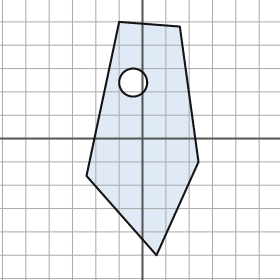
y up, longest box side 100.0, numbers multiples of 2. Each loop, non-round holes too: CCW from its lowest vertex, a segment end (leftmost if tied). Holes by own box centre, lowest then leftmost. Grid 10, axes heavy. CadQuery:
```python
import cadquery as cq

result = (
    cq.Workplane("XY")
    .moveTo(6.0, -50.0)
    .lineTo(24.0, -10.0)
    .lineTo(16.0, 48.0)
    .lineTo(-10.0, 50.0)
    .lineTo(-24.0, -16.0)
    .close()
    .moveTo(-4.0, 24.0)
    .circle(6.0)
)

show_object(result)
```